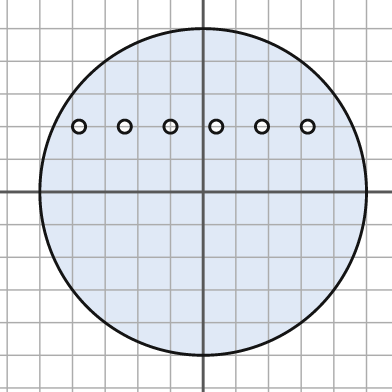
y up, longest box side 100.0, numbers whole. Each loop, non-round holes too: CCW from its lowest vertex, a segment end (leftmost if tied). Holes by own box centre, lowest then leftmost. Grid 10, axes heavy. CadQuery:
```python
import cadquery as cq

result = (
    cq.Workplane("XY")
    .moveTo(0.0, 0.0)
    .circle(50.0)
    .moveTo(-38.0, 20.0)
    .circle(2.0)
    .moveTo(-24.0, 20.0)
    .circle(2.0)
    .moveTo(-10.0, 20.0)
    .circle(2.0)
    .moveTo(4.0, 20.0)
    .circle(2.0)
    .moveTo(18.0, 20.0)
    .circle(2.0)
    .moveTo(32.0, 20.0)
    .circle(2.0)
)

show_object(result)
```